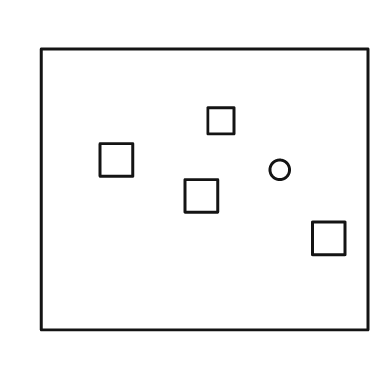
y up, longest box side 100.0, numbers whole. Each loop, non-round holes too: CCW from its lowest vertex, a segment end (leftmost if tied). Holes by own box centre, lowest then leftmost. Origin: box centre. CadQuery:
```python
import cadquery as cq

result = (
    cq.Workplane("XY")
    .moveTo(-50.0, -43.0)
    .lineTo(50.0, -43.0)
    .lineTo(50.0, 43.0)
    .lineTo(-50.0, 43.0)
    .close()
    .moveTo(33.0, -20.0)
    .lineTo(43.0, -20.0)
    .lineTo(43.0, -10.0)
    .lineTo(33.0, -10.0)
    .close()
    .moveTo(-6.0, -7.0)
    .lineTo(4.0, -7.0)
    .lineTo(4.0, 3.0)
    .lineTo(-6.0, 3.0)
    .close()
    .moveTo(23.0, 6.0)
    .circle(3.0)
    .moveTo(-32.0, 4.0)
    .lineTo(-22.0, 4.0)
    .lineTo(-22.0, 14.0)
    .lineTo(-32.0, 14.0)
    .close()
    .moveTo(1.0, 17.0)
    .lineTo(9.0, 17.0)
    .lineTo(9.0, 25.0)
    .lineTo(1.0, 25.0)
    .close()
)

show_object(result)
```